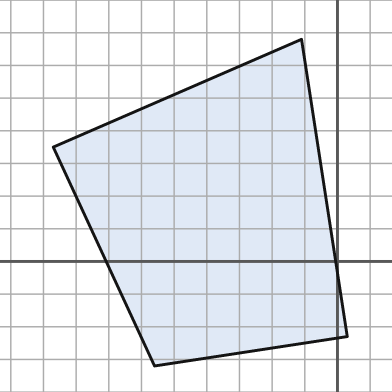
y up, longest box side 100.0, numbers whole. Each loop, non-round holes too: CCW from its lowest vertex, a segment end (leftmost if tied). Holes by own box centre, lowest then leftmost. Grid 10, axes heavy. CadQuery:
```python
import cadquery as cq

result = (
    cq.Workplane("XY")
    .moveTo(-56.0, -32.0)
    .lineTo(3.0, -23.0)
    .lineTo(-11.0, 68.0)
    .lineTo(-87.0, 35.0)
    .close()
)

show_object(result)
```